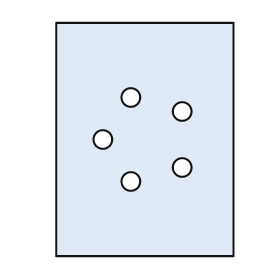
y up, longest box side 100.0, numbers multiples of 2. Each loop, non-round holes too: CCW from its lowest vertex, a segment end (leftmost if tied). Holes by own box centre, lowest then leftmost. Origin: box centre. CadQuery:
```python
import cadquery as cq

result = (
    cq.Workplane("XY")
    .moveTo(-38.0, -50.0)
    .lineTo(38.0, -50.0)
    .lineTo(38.0, 50.0)
    .lineTo(-38.0, 50.0)
    .close()
    .moveTo(-6.0, -18.0)
    .circle(4.0)
    .moveTo(16.0, -12.0)
    .circle(4.0)
    .moveTo(-18.0, 0.0)
    .circle(4.0)
    .moveTo(16.0, 12.0)
    .circle(4.0)
    .moveTo(-6.0, 18.0)
    .circle(4.0)
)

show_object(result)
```